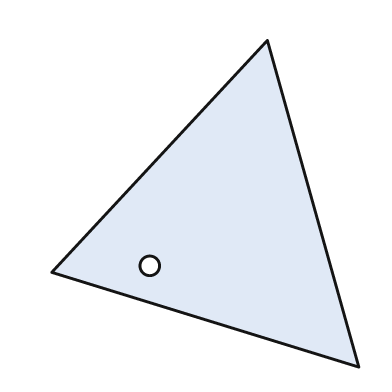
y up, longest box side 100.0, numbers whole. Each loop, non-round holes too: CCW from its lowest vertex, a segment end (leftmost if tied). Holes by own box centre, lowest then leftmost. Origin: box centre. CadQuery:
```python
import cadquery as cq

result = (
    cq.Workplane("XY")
    .moveTo(47.0, -50.0)
    .lineTo(19.0, 50.0)
    .lineTo(-47.0, -21.0)
    .close()
    .moveTo(-17.0, -19.0)
    .circle(3.0)
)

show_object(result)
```